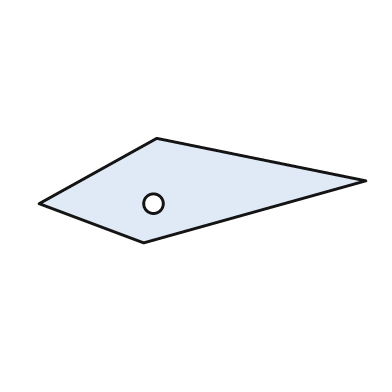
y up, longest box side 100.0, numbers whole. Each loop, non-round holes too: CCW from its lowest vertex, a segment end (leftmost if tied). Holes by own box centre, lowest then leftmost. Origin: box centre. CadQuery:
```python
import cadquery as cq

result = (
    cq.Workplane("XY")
    .moveTo(-18.0, -16.0)
    .lineTo(50.0, 3.0)
    .lineTo(-14.0, 16.0)
    .lineTo(-50.0, -4.0)
    .close()
    .moveTo(-15.0, -4.0)
    .circle(3.0)
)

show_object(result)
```